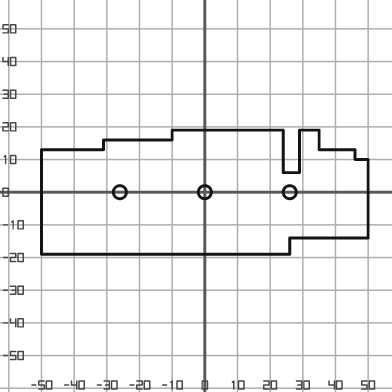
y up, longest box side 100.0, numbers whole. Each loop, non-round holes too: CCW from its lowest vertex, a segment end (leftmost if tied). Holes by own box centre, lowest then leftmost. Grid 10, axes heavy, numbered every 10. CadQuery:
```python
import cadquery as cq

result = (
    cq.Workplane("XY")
    .moveTo(-50.0, -19.0)
    .lineTo(26.0, -19.0)
    .lineTo(26.0, -14.0)
    .lineTo(50.0, -14.0)
    .lineTo(50.0, 10.0)
    .lineTo(46.0, 10.0)
    .lineTo(46.0, 13.0)
    .lineTo(35.0, 13.0)
    .lineTo(35.0, 19.0)
    .lineTo(29.0, 19.0)
    .lineTo(29.0, 6.0)
    .lineTo(24.0, 6.0)
    .lineTo(24.0, 19.0)
    .lineTo(-10.0, 19.0)
    .lineTo(-10.0, 16.0)
    .lineTo(-31.0, 16.0)
    .lineTo(-31.0, 13.0)
    .lineTo(-50.0, 13.0)
    .close()
    .moveTo(-26.0, 0.0)
    .circle(2.0)
    .moveTo(0.0, 0.0)
    .circle(2.0)
    .moveTo(26.0, 0.0)
    .circle(2.0)
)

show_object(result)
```